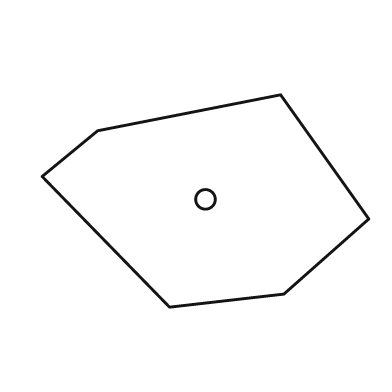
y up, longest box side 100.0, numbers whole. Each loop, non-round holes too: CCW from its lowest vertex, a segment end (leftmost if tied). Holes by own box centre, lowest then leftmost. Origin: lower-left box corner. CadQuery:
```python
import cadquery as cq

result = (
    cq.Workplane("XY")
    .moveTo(39.0, 0.0)
    .lineTo(74.0, 4.0)
    .lineTo(100.0, 27.0)
    .lineTo(73.0, 65.0)
    .lineTo(17.0, 54.0)
    .lineTo(0.0, 40.0)
    .close()
    .moveTo(50.0, 33.0)
    .circle(3.0)
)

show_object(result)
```